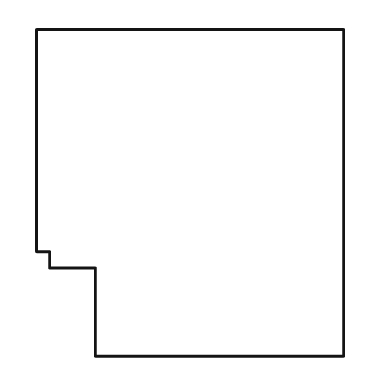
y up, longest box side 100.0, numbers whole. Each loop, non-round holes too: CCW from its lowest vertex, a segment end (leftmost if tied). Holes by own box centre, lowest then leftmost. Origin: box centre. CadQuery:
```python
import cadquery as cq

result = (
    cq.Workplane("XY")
    .moveTo(-29.0, -50.0)
    .lineTo(47.0, -50.0)
    .lineTo(47.0, 50.0)
    .lineTo(-47.0, 50.0)
    .lineTo(-47.0, -18.0)
    .lineTo(-43.0, -18.0)
    .lineTo(-43.0, -23.0)
    .lineTo(-29.0, -23.0)
    .close()
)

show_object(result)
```